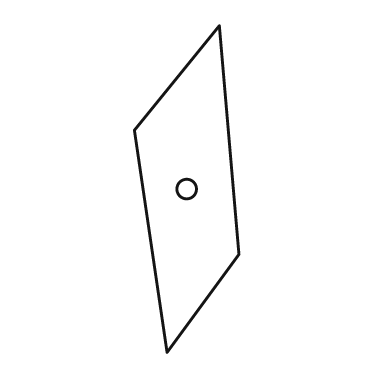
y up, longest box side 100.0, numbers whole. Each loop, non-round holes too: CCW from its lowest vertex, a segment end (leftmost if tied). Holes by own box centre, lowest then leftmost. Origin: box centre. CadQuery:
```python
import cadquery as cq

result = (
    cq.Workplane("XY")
    .moveTo(-6.0, -50.0)
    .lineTo(16.0, -20.0)
    .lineTo(10.0, 50.0)
    .lineTo(-16.0, 18.0)
    .close()
    .moveTo(0.0, 0.0)
    .circle(3.0)
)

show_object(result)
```